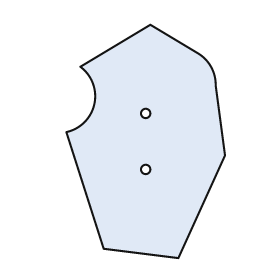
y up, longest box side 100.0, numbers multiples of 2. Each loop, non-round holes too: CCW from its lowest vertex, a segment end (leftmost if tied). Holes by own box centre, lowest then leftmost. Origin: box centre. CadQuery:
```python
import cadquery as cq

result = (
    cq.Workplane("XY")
    .moveTo(14.0, -50.0)
    .lineTo(34.0, -6.0)
    .lineTo(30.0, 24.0)
    .threePointArc((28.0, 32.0), (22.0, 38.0))
    .lineTo(2.0, 50.0)
    .lineTo(-28.0, 32.0)
    .threePointArc((-22.0, 16.0), (-34.0, 4.0))
    .lineTo(-18.0, -46.0)
    .close()
    .moveTo(0.0, -12.0)
    .circle(2.0)
    .moveTo(0.0, 12.0)
    .circle(2.0)
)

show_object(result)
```